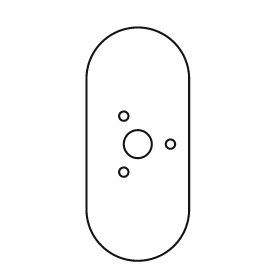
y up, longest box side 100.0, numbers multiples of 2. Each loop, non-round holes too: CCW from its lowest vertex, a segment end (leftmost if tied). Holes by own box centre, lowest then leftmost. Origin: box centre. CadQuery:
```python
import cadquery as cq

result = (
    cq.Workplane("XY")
    .moveTo(-22.0, -28.0)
    .threePointArc((0.0, -50.0), (22.0, -28.0))
    .lineTo(22.0, 28.0)
    .threePointArc((0.0, 50.0), (-22.0, 28.0))
    .close()
    .moveTo(-6.0, -12.0)
    .circle(2.0)
    .moveTo(0.0, 0.0)
    .circle(6.0)
    .moveTo(14.0, 0.0)
    .circle(2.0)
    .moveTo(-6.0, 12.0)
    .circle(2.0)
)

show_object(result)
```